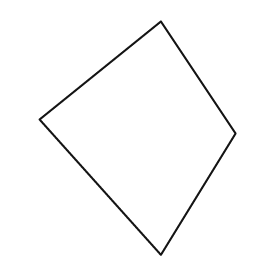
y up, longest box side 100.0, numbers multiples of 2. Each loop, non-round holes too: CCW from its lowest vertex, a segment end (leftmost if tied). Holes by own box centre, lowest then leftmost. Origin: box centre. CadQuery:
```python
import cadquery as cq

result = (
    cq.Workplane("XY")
    .moveTo(10.0, -50.0)
    .lineTo(42.0, 2.0)
    .lineTo(10.0, 50.0)
    .lineTo(-42.0, 8.0)
    .close()
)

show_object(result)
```